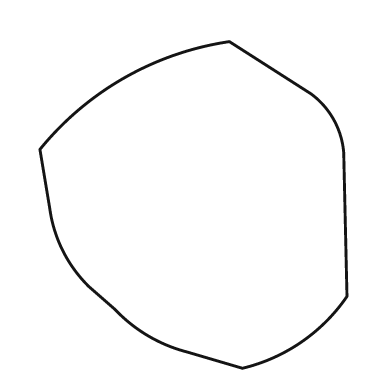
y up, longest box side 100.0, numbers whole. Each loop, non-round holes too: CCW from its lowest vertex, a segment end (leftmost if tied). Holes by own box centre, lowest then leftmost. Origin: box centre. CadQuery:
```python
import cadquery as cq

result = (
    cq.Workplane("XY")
    .moveTo(15.0, -50.0)
    .threePointArc((33.0, -42.0), (47.0, -28.0))
    .lineTo(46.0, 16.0)
    .threePointArc((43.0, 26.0), (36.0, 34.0))
    .lineTo(11.0, 50.0)
    .threePointArc((-21.0, 39.0), (-47.0, 17.0))
    .lineTo(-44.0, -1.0)
    .threePointArc((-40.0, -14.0), (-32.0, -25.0))
    .lineTo(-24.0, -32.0)
    .threePointArc((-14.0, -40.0), (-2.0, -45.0))
    .close()
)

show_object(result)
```